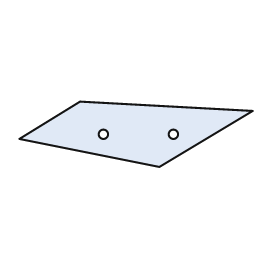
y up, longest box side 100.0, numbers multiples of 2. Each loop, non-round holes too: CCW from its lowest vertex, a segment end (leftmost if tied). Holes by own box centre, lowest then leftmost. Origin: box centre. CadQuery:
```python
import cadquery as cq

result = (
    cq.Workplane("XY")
    .moveTo(10.0, -14.0)
    .lineTo(50.0, 10.0)
    .lineTo(-24.0, 14.0)
    .lineTo(-50.0, -2.0)
    .close()
    .moveTo(-14.0, 0.0)
    .circle(2.0)
    .moveTo(16.0, 0.0)
    .circle(2.0)
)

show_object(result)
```